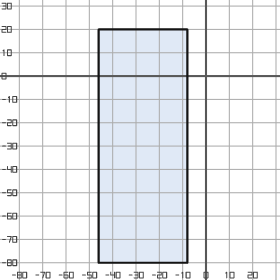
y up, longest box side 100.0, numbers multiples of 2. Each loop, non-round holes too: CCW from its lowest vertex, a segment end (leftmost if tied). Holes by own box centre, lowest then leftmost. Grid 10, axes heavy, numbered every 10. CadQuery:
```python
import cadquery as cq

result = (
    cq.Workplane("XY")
    .moveTo(-46.0, -80.0)
    .lineTo(-8.0, -80.0)
    .lineTo(-8.0, 20.0)
    .lineTo(-46.0, 20.0)
    .close()
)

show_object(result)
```